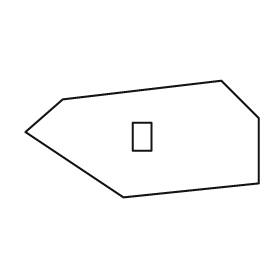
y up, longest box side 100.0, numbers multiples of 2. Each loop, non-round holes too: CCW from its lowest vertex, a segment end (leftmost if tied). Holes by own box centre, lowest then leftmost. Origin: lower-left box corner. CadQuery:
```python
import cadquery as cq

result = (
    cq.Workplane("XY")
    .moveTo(42.0, 0.0)
    .lineTo(100.0, 6.0)
    .lineTo(100.0, 34.0)
    .lineTo(84.0, 50.0)
    .lineTo(16.0, 42.0)
    .lineTo(0.0, 28.0)
    .close()
    .moveTo(46.0, 20.0)
    .lineTo(54.0, 20.0)
    .lineTo(54.0, 32.0)
    .lineTo(46.0, 32.0)
    .close()
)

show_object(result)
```